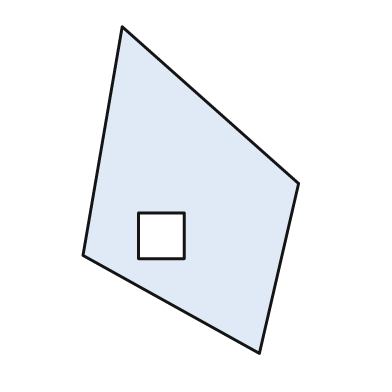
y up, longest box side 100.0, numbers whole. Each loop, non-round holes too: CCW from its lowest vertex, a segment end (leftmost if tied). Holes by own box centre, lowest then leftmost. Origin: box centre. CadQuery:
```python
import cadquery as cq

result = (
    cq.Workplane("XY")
    .moveTo(21.0, -50.0)
    .lineTo(33.0, 2.0)
    .lineTo(-21.0, 50.0)
    .lineTo(-33.0, -20.0)
    .close()
    .moveTo(-16.0, -21.0)
    .lineTo(-2.0, -21.0)
    .lineTo(-2.0, -7.0)
    .lineTo(-16.0, -7.0)
    .close()
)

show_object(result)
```